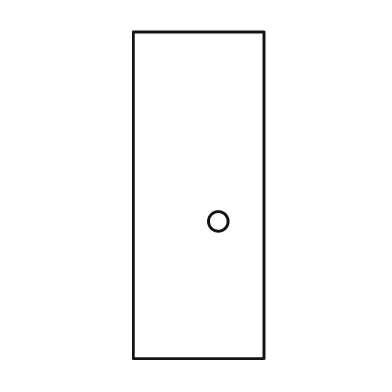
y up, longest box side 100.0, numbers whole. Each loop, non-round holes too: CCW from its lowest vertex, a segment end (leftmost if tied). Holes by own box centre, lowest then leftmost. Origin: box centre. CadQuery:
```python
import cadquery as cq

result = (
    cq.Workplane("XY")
    .moveTo(-20.0, -50.0)
    .lineTo(20.0, -50.0)
    .lineTo(20.0, 50.0)
    .lineTo(-20.0, 50.0)
    .close()
    .moveTo(6.0, -8.0)
    .circle(3.0)
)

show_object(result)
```